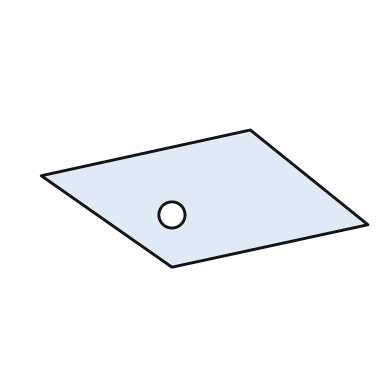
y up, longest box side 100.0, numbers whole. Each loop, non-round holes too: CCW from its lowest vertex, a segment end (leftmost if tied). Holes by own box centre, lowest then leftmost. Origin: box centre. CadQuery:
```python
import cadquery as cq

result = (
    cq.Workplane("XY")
    .moveTo(-10.0, -21.0)
    .lineTo(50.0, -8.0)
    .lineTo(14.0, 21.0)
    .lineTo(-50.0, 7.0)
    .close()
    .moveTo(-10.0, -5.0)
    .circle(4.0)
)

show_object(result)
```